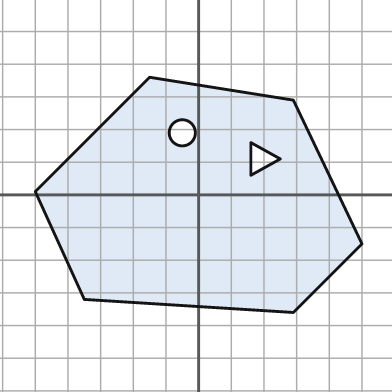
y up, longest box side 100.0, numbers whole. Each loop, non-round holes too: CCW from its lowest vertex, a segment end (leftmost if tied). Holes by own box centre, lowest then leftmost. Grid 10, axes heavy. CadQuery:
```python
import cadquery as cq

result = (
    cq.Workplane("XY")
    .moveTo(29.0, -36.0)
    .lineTo(50.0, -15.0)
    .lineTo(29.0, 29.0)
    .lineTo(-15.0, 36.0)
    .lineTo(-50.0, 1.0)
    .lineTo(-35.0, -32.0)
    .close()
    .moveTo(16.0, 6.0)
    .lineTo(25.0, 11.0)
    .lineTo(16.0, 16.0)
    .close()
    .moveTo(-5.0, 19.0)
    .circle(4.0)
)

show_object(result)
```